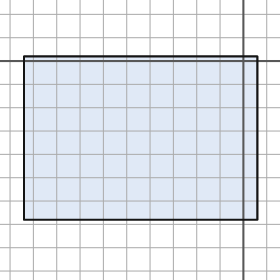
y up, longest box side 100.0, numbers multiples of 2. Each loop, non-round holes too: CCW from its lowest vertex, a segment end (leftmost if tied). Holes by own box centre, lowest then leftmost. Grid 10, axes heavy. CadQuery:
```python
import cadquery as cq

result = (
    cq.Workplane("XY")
    .moveTo(-94.0, -68.0)
    .lineTo(6.0, -68.0)
    .lineTo(6.0, 2.0)
    .lineTo(-94.0, 2.0)
    .close()
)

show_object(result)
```